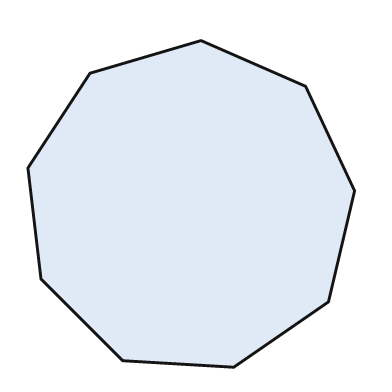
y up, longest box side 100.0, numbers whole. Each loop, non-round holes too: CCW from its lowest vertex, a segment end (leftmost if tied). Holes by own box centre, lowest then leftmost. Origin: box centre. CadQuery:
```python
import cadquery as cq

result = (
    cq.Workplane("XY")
    .moveTo(13.0, -50.0)
    .lineTo(42.0, -30.0)
    .lineTo(50.0, 4.0)
    .lineTo(35.0, 36.0)
    .lineTo(3.0, 50.0)
    .lineTo(-31.0, 40.0)
    .lineTo(-50.0, 11.0)
    .lineTo(-46.0, -23.0)
    .lineTo(-21.0, -48.0)
    .close()
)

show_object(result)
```